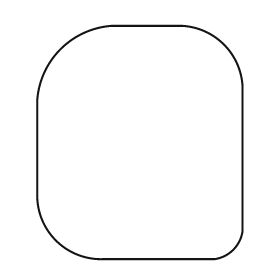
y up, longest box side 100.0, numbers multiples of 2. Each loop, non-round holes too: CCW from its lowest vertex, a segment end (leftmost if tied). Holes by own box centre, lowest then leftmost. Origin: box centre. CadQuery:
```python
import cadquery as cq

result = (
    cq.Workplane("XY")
    .moveTo(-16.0, -50.0)
    .lineTo(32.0, -50.0)
    .threePointArc((40.0, -46.0), (44.0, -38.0))
    .lineTo(44.0, 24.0)
    .threePointArc((36.0, 42.0), (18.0, 50.0))
    .lineTo(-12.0, 50.0)
    .threePointArc((-34.0, 40.0), (-44.0, 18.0))
    .lineTo(-44.0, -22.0)
    .threePointArc((-36.0, -42.0), (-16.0, -50.0))
    .close()
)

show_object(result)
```